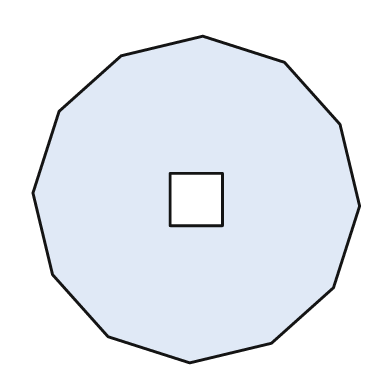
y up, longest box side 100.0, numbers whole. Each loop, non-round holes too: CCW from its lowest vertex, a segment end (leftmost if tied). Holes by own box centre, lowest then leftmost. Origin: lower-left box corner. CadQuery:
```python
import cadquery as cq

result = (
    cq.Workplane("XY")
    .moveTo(48.0, 0.0)
    .lineTo(73.0, 6.0)
    .lineTo(92.0, 23.0)
    .lineTo(100.0, 48.0)
    .lineTo(94.0, 73.0)
    .lineTo(77.0, 92.0)
    .lineTo(52.0, 100.0)
    .lineTo(27.0, 94.0)
    .lineTo(8.0, 77.0)
    .lineTo(0.0, 52.0)
    .lineTo(6.0, 27.0)
    .lineTo(23.0, 8.0)
    .close()
    .moveTo(42.0, 42.0)
    .lineTo(58.0, 42.0)
    .lineTo(58.0, 58.0)
    .lineTo(42.0, 58.0)
    .close()
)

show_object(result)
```